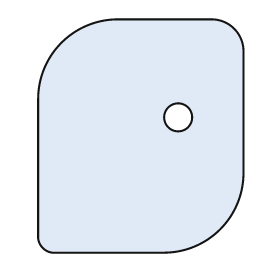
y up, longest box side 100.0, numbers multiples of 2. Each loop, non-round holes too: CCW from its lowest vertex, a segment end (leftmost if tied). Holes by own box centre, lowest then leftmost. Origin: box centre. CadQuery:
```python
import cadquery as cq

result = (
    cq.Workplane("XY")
    .moveTo(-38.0, -50.0)
    .lineTo(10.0, -50.0)
    .threePointArc((34.0, -40.0), (44.0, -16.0))
    .lineTo(44.0, 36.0)
    .threePointArc((40.0, 46.0), (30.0, 50.0))
    .lineTo(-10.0, 50.0)
    .threePointArc((-34.0, 40.0), (-44.0, 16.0))
    .lineTo(-44.0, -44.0)
    .threePointArc((-42.0, -48.0), (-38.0, -50.0))
    .close()
    .moveTo(16.0, 8.0)
    .circle(6.0)
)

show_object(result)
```